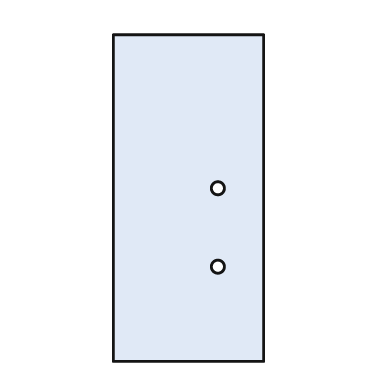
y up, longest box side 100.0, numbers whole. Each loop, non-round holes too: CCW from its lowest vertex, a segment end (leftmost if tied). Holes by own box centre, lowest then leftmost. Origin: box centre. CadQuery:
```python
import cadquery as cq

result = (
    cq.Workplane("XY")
    .moveTo(-23.0, -50.0)
    .lineTo(23.0, -50.0)
    .lineTo(23.0, 50.0)
    .lineTo(-23.0, 50.0)
    .close()
    .moveTo(9.0, -21.0)
    .circle(2.0)
    .moveTo(9.0, 3.0)
    .circle(2.0)
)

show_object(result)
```